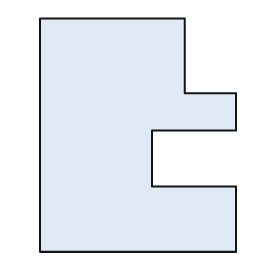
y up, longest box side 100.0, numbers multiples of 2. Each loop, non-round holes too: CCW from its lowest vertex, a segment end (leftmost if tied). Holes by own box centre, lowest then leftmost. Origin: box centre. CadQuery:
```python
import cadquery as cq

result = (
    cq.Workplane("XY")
    .moveTo(-42.0, -50.0)
    .lineTo(42.0, -50.0)
    .lineTo(42.0, -22.0)
    .lineTo(6.0, -22.0)
    .lineTo(6.0, 2.0)
    .lineTo(42.0, 2.0)
    .lineTo(42.0, 18.0)
    .lineTo(20.0, 18.0)
    .lineTo(20.0, 50.0)
    .lineTo(-42.0, 50.0)
    .close()
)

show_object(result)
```